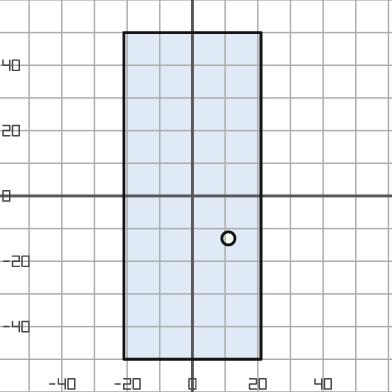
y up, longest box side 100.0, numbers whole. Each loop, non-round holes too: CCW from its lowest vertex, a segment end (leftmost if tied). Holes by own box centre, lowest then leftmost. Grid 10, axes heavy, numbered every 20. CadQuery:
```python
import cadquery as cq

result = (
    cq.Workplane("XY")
    .moveTo(-21.0, -50.0)
    .lineTo(21.0, -50.0)
    .lineTo(21.0, 50.0)
    .lineTo(-21.0, 50.0)
    .close()
    .moveTo(11.0, -13.0)
    .circle(2.0)
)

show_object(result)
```